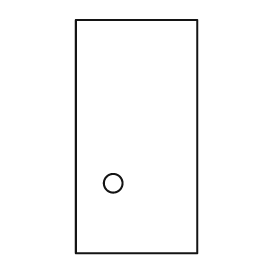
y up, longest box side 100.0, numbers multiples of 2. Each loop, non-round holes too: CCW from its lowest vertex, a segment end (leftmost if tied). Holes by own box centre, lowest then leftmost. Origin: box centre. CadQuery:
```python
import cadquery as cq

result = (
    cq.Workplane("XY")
    .moveTo(-26.0, -50.0)
    .lineTo(26.0, -50.0)
    .lineTo(26.0, 50.0)
    .lineTo(-26.0, 50.0)
    .close()
    .moveTo(-10.0, -20.0)
    .circle(4.0)
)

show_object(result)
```